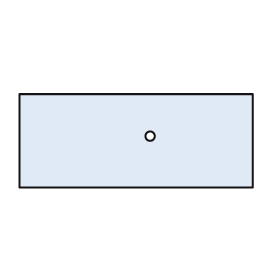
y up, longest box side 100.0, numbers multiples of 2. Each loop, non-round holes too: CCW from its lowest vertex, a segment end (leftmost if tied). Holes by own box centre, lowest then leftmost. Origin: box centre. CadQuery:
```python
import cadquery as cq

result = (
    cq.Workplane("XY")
    .moveTo(-50.0, -20.0)
    .lineTo(50.0, -20.0)
    .lineTo(50.0, 20.0)
    .lineTo(-50.0, 20.0)
    .close()
    .moveTo(6.0, 2.0)
    .circle(2.0)
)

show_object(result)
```